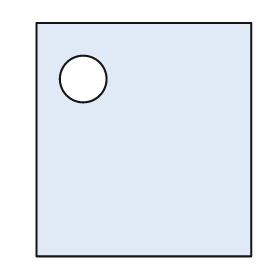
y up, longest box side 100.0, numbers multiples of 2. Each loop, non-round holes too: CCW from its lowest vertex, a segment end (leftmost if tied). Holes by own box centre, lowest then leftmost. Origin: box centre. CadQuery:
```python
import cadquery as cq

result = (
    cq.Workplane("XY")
    .moveTo(-46.0, -50.0)
    .lineTo(46.0, -50.0)
    .lineTo(46.0, 50.0)
    .lineTo(-46.0, 50.0)
    .close()
    .moveTo(-26.0, 26.0)
    .circle(10.0)
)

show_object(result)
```